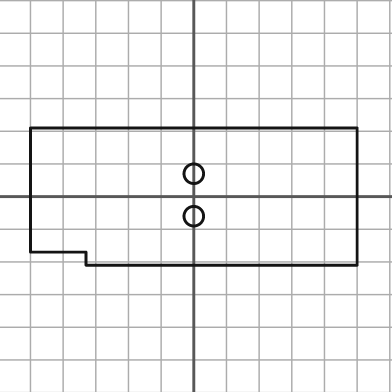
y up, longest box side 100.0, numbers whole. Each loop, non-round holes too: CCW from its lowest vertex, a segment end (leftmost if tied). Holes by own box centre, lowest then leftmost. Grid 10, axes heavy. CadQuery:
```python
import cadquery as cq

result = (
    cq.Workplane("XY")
    .moveTo(-33.0, -21.0)
    .lineTo(50.0, -21.0)
    .lineTo(50.0, 21.0)
    .lineTo(-50.0, 21.0)
    .lineTo(-50.0, -17.0)
    .lineTo(-33.0, -17.0)
    .close()
    .moveTo(0.0, -6.0)
    .circle(3.0)
    .moveTo(0.0, 7.0)
    .circle(3.0)
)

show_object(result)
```